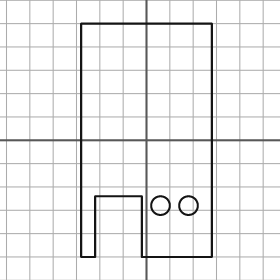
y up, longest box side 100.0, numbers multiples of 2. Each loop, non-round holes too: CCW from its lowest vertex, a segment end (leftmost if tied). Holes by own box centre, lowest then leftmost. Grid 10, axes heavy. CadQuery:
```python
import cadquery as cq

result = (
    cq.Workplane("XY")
    .moveTo(-28.0, -50.0)
    .lineTo(-22.0, -50.0)
    .lineTo(-22.0, -24.0)
    .lineTo(-2.0, -24.0)
    .lineTo(-2.0, -50.0)
    .lineTo(28.0, -50.0)
    .lineTo(28.0, 50.0)
    .lineTo(-28.0, 50.0)
    .close()
    .moveTo(6.0, -28.0)
    .circle(4.0)
    .moveTo(18.0, -28.0)
    .circle(4.0)
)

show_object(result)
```